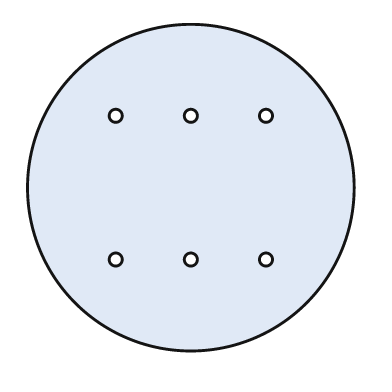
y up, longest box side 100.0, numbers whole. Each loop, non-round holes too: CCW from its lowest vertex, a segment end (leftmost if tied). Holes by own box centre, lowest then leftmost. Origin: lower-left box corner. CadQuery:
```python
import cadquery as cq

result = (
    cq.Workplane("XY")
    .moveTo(50.0, 50.0)
    .circle(50.0)
    .moveTo(27.0, 28.0)
    .circle(2.0)
    .moveTo(50.0, 28.0)
    .circle(2.0)
    .moveTo(73.0, 28.0)
    .circle(2.0)
    .moveTo(27.0, 72.0)
    .circle(2.0)
    .moveTo(50.0, 72.0)
    .circle(2.0)
    .moveTo(73.0, 72.0)
    .circle(2.0)
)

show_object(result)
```